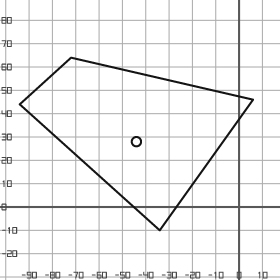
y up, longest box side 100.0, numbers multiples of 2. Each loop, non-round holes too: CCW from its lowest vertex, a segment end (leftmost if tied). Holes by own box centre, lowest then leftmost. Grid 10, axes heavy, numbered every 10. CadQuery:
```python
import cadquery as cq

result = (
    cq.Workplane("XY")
    .moveTo(-34.0, -10.0)
    .lineTo(6.0, 46.0)
    .lineTo(-72.0, 64.0)
    .lineTo(-94.0, 44.0)
    .close()
    .moveTo(-44.0, 28.0)
    .circle(2.0)
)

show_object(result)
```